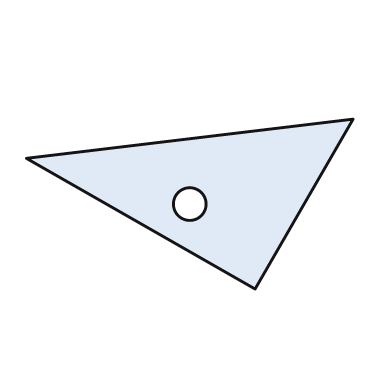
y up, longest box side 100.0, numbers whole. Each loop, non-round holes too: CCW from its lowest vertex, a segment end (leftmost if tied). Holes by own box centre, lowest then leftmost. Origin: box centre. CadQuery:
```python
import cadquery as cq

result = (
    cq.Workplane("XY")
    .moveTo(20.0, -26.0)
    .lineTo(50.0, 26.0)
    .lineTo(-50.0, 14.0)
    .close()
    .moveTo(0.0, 0.0)
    .circle(5.0)
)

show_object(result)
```